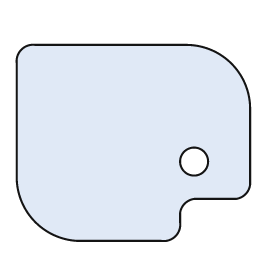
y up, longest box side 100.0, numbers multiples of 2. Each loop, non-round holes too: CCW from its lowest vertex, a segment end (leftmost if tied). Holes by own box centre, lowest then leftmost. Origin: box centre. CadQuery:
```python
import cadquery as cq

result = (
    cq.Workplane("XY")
    .moveTo(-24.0, -42.0)
    .lineTo(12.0, -42.0)
    .threePointArc((18.0, -40.0), (20.0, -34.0))
    .lineTo(20.0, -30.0)
    .threePointArc((22.0, -26.0), (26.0, -24.0))
    .lineTo(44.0, -24.0)
    .threePointArc((48.0, -22.0), (50.0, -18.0))
    .lineTo(50.0, 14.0)
    .threePointArc((42.0, 34.0), (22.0, 42.0))
    .lineTo(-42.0, 42.0)
    .threePointArc((-48.0, 40.0), (-50.0, 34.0))
    .lineTo(-50.0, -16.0)
    .threePointArc((-42.0, -34.0), (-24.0, -42.0))
    .close()
    .moveTo(26.0, -8.0)
    .circle(6.0)
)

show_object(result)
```